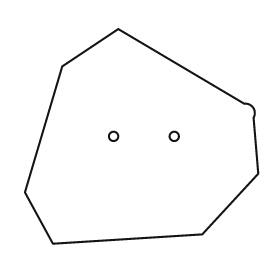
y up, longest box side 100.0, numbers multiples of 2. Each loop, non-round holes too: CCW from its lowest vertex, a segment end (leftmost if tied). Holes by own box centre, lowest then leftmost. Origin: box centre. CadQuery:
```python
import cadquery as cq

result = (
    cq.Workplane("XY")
    .moveTo(-38.0, -46.0)
    .lineTo(26.0, -42.0)
    .lineTo(50.0, -16.0)
    .lineTo(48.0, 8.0)
    .threePointArc((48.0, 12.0), (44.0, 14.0))
    .lineTo(-10.0, 46.0)
    .lineTo(-34.0, 30.0)
    .lineTo(-50.0, -24.0)
    .close()
    .moveTo(-12.0, 0.0)
    .circle(2.0)
    .moveTo(14.0, 0.0)
    .circle(2.0)
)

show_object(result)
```